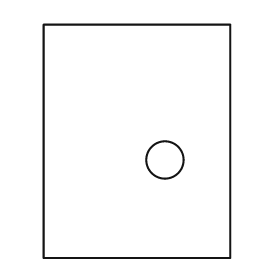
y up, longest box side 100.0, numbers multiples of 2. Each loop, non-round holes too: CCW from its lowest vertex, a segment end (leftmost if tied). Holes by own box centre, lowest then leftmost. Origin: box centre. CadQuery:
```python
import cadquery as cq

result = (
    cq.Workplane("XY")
    .moveTo(-40.0, -50.0)
    .lineTo(40.0, -50.0)
    .lineTo(40.0, 50.0)
    .lineTo(-40.0, 50.0)
    .close()
    .moveTo(12.0, -8.0)
    .circle(8.0)
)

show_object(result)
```